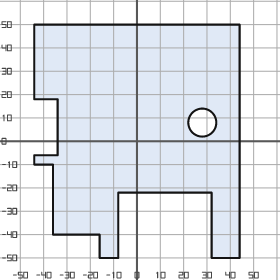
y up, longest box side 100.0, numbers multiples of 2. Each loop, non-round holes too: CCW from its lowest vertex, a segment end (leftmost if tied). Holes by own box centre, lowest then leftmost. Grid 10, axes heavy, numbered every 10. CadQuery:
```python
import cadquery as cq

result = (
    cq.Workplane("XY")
    .moveTo(-16.0, -50.0)
    .lineTo(-8.0, -50.0)
    .lineTo(-8.0, -22.0)
    .lineTo(32.0, -22.0)
    .lineTo(32.0, -50.0)
    .lineTo(44.0, -50.0)
    .lineTo(44.0, 50.0)
    .lineTo(-44.0, 50.0)
    .lineTo(-44.0, 18.0)
    .lineTo(-34.0, 18.0)
    .lineTo(-34.0, -6.0)
    .lineTo(-44.0, -6.0)
    .lineTo(-44.0, -10.0)
    .lineTo(-36.0, -10.0)
    .lineTo(-36.0, -40.0)
    .lineTo(-16.0, -40.0)
    .close()
    .moveTo(28.0, 8.0)
    .circle(6.0)
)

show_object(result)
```